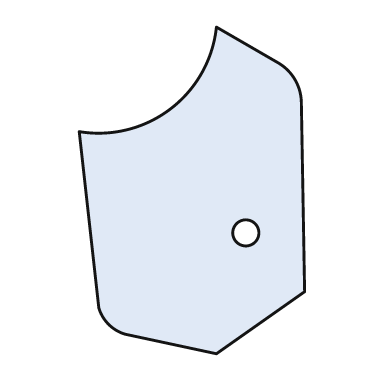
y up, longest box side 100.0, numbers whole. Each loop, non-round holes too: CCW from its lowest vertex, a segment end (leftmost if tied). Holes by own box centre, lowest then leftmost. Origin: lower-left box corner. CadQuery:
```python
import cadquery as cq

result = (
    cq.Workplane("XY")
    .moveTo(42.0, 0.0)
    .lineTo(69.0, 19.0)
    .lineTo(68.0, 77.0)
    .threePointArc((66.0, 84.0), (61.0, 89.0))
    .lineTo(42.0, 100.0)
    .threePointArc((28.0, 75.0), (0.0, 68.0))
    .lineTo(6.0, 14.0)
    .threePointArc((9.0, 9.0), (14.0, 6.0))
    .close()
    .moveTo(51.0, 37.0)
    .circle(4.0)
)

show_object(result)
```